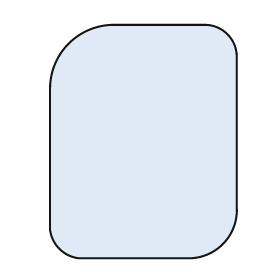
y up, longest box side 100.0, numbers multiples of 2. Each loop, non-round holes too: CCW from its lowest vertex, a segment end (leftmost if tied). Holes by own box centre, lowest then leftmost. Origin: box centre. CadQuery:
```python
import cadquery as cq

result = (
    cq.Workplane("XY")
    .moveTo(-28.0, -50.0)
    .lineTo(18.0, -50.0)
    .threePointArc((34.0, -44.0), (40.0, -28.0))
    .lineTo(40.0, 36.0)
    .threePointArc((36.0, 46.0), (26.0, 50.0))
    .lineTo(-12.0, 50.0)
    .threePointArc((-32.0, 42.0), (-40.0, 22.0))
    .lineTo(-40.0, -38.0)
    .threePointArc((-36.0, -46.0), (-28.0, -50.0))
    .close()
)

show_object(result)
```